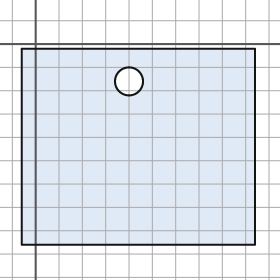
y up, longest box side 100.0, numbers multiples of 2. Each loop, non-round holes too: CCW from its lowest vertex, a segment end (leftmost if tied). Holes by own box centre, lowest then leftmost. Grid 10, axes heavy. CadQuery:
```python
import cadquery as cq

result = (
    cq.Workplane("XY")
    .moveTo(-6.0, -86.0)
    .lineTo(94.0, -86.0)
    .lineTo(94.0, -2.0)
    .lineTo(-6.0, -2.0)
    .close()
    .moveTo(40.0, -16.0)
    .circle(6.0)
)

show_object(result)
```